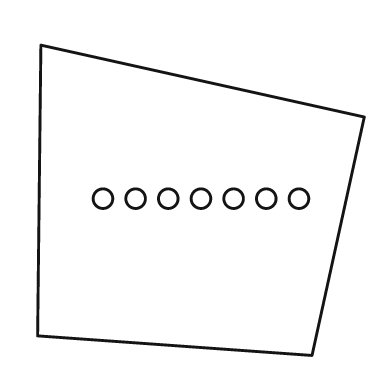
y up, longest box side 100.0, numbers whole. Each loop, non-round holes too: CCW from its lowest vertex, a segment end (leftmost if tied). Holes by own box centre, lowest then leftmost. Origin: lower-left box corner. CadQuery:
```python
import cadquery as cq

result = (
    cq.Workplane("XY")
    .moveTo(84.0, 0.0)
    .lineTo(100.0, 73.0)
    .lineTo(1.0, 95.0)
    .lineTo(0.0, 6.0)
    .close()
    .moveTo(20.0, 48.0)
    .circle(3.0)
    .moveTo(30.0, 48.0)
    .circle(3.0)
    .moveTo(40.0, 48.0)
    .circle(3.0)
    .moveTo(50.0, 48.0)
    .circle(3.0)
    .moveTo(60.0, 48.0)
    .circle(3.0)
    .moveTo(70.0, 48.0)
    .circle(3.0)
    .moveTo(80.0, 48.0)
    .circle(3.0)
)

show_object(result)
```